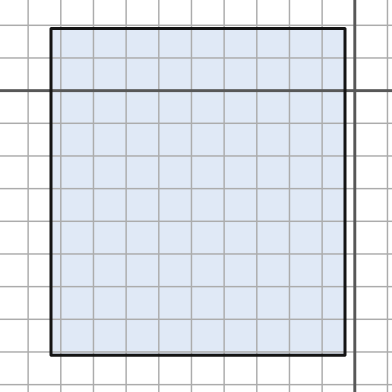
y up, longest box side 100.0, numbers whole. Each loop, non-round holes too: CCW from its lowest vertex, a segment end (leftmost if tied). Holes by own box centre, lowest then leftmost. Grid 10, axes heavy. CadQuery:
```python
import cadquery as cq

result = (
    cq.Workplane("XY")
    .moveTo(-93.0, -81.0)
    .lineTo(-3.0, -81.0)
    .lineTo(-3.0, 19.0)
    .lineTo(-93.0, 19.0)
    .close()
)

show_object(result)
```